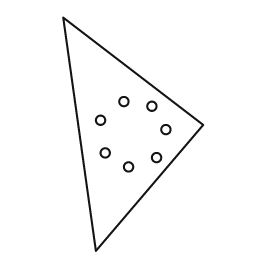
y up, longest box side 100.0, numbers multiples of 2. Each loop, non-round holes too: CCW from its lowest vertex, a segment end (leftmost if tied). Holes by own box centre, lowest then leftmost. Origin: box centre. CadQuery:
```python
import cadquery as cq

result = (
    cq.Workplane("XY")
    .moveTo(-16.0, -50.0)
    .lineTo(30.0, 4.0)
    .lineTo(-30.0, 50.0)
    .close()
    .moveTo(-2.0, -14.0)
    .circle(2.0)
    .moveTo(10.0, -10.0)
    .circle(2.0)
    .moveTo(-12.0, -8.0)
    .circle(2.0)
    .moveTo(14.0, 2.0)
    .circle(2.0)
    .moveTo(-14.0, 6.0)
    .circle(2.0)
    .moveTo(8.0, 12.0)
    .circle(2.0)
    .moveTo(-4.0, 14.0)
    .circle(2.0)
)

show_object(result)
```